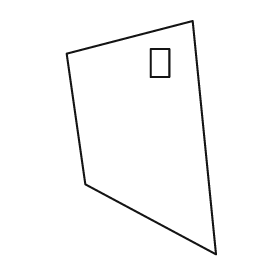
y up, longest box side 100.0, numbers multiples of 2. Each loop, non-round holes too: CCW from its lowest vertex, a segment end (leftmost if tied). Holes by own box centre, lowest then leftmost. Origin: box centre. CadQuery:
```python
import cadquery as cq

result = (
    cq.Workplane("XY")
    .moveTo(32.0, -50.0)
    .lineTo(22.0, 50.0)
    .lineTo(-32.0, 36.0)
    .lineTo(-24.0, -20.0)
    .close()
    .moveTo(4.0, 26.0)
    .lineTo(12.0, 26.0)
    .lineTo(12.0, 38.0)
    .lineTo(4.0, 38.0)
    .close()
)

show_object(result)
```